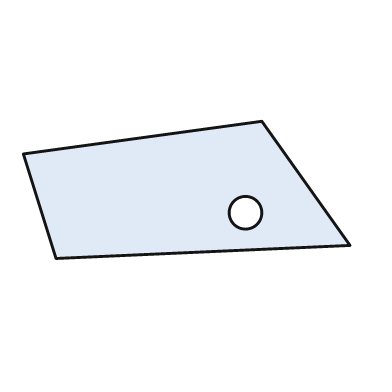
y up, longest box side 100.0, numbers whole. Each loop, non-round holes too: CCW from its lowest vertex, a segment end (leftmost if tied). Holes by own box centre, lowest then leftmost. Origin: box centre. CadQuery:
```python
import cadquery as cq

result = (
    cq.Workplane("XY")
    .moveTo(-40.0, -21.0)
    .lineTo(50.0, -17.0)
    .lineTo(23.0, 21.0)
    .lineTo(-50.0, 11.0)
    .close()
    .moveTo(18.0, -7.0)
    .circle(5.0)
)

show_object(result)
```